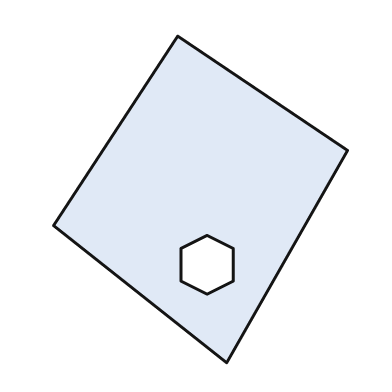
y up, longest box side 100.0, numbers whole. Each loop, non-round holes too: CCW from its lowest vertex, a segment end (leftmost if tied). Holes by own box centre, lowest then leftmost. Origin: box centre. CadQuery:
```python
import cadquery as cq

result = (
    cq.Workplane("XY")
    .moveTo(8.0, -50.0)
    .lineTo(45.0, 15.0)
    .lineTo(-7.0, 50.0)
    .lineTo(-45.0, -8.0)
    .close()
    .moveTo(2.0, -29.0)
    .lineTo(10.0, -25.0)
    .lineTo(10.0, -15.0)
    .lineTo(2.0, -11.0)
    .lineTo(-6.0, -15.0)
    .lineTo(-6.0, -25.0)
    .close()
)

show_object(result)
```